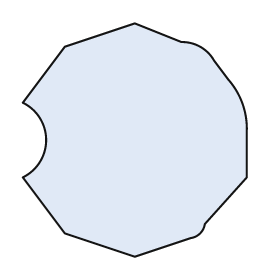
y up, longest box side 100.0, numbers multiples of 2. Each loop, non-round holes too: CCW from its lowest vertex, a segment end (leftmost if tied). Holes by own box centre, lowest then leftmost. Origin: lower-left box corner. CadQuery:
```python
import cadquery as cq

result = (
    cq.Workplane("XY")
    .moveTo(48.0, 0.0)
    .lineTo(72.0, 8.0)
    .threePointArc((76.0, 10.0), (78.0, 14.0))
    .lineTo(96.0, 34.0)
    .lineTo(96.0, 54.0)
    .threePointArc((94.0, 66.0), (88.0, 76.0))
    .lineTo(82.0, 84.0)
    .threePointArc((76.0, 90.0), (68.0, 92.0))
    .lineTo(48.0, 100.0)
    .lineTo(18.0, 90.0)
    .lineTo(0.0, 66.0)
    .threePointArc((10.0, 50.0), (0.0, 34.0))
    .lineTo(18.0, 10.0)
    .close()
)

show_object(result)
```